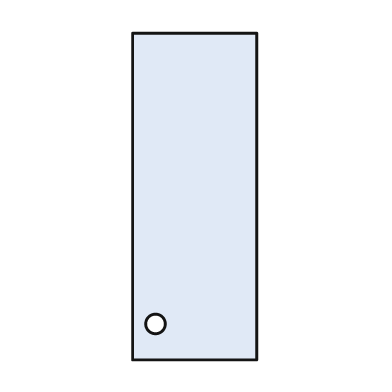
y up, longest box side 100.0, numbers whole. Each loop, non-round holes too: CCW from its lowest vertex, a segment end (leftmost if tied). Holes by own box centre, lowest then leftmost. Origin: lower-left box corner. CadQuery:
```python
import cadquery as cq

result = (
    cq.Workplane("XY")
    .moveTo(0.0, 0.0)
    .lineTo(38.0, 0.0)
    .lineTo(38.0, 100.0)
    .lineTo(0.0, 100.0)
    .close()
    .moveTo(7.0, 11.0)
    .circle(3.0)
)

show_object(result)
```